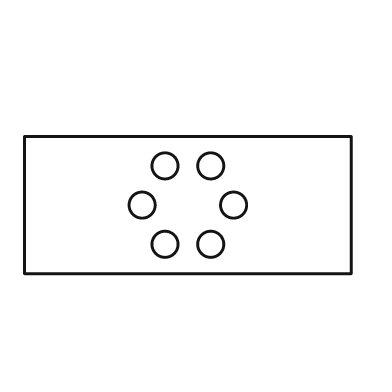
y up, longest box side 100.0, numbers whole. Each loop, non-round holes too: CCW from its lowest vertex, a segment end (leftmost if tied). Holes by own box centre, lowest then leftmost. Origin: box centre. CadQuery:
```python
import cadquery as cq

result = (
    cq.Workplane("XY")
    .moveTo(-50.0, -21.0)
    .lineTo(50.0, -21.0)
    .lineTo(50.0, 21.0)
    .lineTo(-50.0, 21.0)
    .close()
    .moveTo(-7.0, -12.0)
    .circle(4.0)
    .moveTo(7.0, -12.0)
    .circle(4.0)
    .moveTo(-14.0, 0.0)
    .circle(4.0)
    .moveTo(14.0, 0.0)
    .circle(4.0)
    .moveTo(-7.0, 12.0)
    .circle(4.0)
    .moveTo(7.0, 12.0)
    .circle(4.0)
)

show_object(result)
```